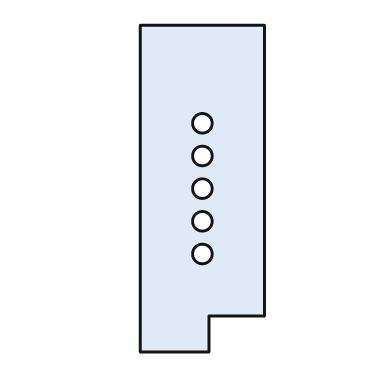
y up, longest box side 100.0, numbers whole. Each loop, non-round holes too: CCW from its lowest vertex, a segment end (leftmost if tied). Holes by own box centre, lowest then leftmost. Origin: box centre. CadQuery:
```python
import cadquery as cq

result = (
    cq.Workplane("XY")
    .moveTo(-19.0, -50.0)
    .lineTo(2.0, -50.0)
    .lineTo(2.0, -39.0)
    .lineTo(19.0, -39.0)
    .lineTo(19.0, 50.0)
    .lineTo(-19.0, 50.0)
    .close()
    .moveTo(0.0, -20.0)
    .circle(3.0)
    .moveTo(0.0, -10.0)
    .circle(3.0)
    .moveTo(0.0, 0.0)
    .circle(3.0)
    .moveTo(0.0, 10.0)
    .circle(3.0)
    .moveTo(0.0, 20.0)
    .circle(3.0)
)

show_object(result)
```